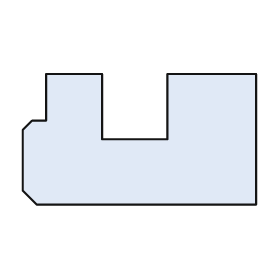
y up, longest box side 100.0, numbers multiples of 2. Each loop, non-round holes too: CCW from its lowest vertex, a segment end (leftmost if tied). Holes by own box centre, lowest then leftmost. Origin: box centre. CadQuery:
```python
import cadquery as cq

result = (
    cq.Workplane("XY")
    .moveTo(-44.0, -28.0)
    .lineTo(50.0, -28.0)
    .lineTo(50.0, 28.0)
    .lineTo(12.0, 28.0)
    .lineTo(12.0, 0.0)
    .lineTo(-16.0, 0.0)
    .lineTo(-16.0, 28.0)
    .lineTo(-40.0, 28.0)
    .lineTo(-40.0, 8.0)
    .lineTo(-46.0, 8.0)
    .lineTo(-50.0, 4.0)
    .lineTo(-50.0, -22.0)
    .close()
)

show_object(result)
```